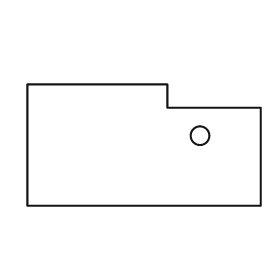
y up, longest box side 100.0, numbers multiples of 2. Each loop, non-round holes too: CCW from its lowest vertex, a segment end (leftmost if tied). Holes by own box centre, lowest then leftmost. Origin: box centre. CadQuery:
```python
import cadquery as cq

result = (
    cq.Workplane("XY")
    .moveTo(-50.0, -26.0)
    .lineTo(50.0, -26.0)
    .lineTo(50.0, 16.0)
    .lineTo(10.0, 16.0)
    .lineTo(10.0, 26.0)
    .lineTo(-50.0, 26.0)
    .close()
    .moveTo(24.0, 4.0)
    .circle(4.0)
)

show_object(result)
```